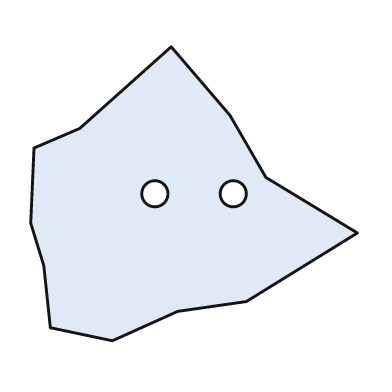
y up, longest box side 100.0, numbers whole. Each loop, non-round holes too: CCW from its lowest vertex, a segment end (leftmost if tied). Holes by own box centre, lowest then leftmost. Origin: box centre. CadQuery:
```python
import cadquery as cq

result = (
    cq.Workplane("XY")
    .moveTo(-25.0, -45.0)
    .lineTo(-5.0, -36.0)
    .lineTo(16.0, -33.0)
    .lineTo(50.0, -12.0)
    .lineTo(22.0, 5.0)
    .lineTo(11.0, 24.0)
    .lineTo(-7.0, 45.0)
    .lineTo(-35.0, 20.0)
    .lineTo(-49.0, 14.0)
    .lineTo(-50.0, -9.0)
    .lineTo(-46.0, -22.0)
    .lineTo(-44.0, -41.0)
    .close()
    .moveTo(-12.0, 0.0)
    .circle(4.0)
    .moveTo(12.0, 0.0)
    .circle(4.0)
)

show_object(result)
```